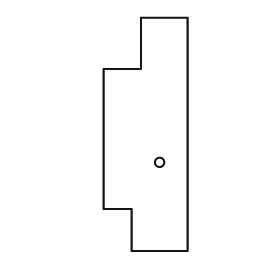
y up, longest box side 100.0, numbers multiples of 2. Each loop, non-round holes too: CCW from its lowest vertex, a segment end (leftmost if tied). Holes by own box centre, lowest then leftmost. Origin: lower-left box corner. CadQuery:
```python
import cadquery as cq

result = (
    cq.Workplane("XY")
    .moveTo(12.0, 0.0)
    .lineTo(36.0, 0.0)
    .lineTo(36.0, 100.0)
    .lineTo(16.0, 100.0)
    .lineTo(16.0, 78.0)
    .lineTo(0.0, 78.0)
    .lineTo(0.0, 18.0)
    .lineTo(12.0, 18.0)
    .close()
    .moveTo(24.0, 38.0)
    .circle(2.0)
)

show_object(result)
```